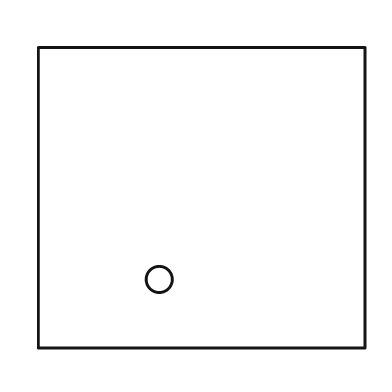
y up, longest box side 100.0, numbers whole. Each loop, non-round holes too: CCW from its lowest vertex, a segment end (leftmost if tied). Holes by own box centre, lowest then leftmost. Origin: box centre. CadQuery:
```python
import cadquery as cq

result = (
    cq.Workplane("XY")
    .moveTo(-50.0, -46.0)
    .lineTo(50.0, -46.0)
    .lineTo(50.0, 46.0)
    .lineTo(-50.0, 46.0)
    .close()
    .moveTo(-13.0, -25.0)
    .circle(4.0)
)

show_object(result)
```